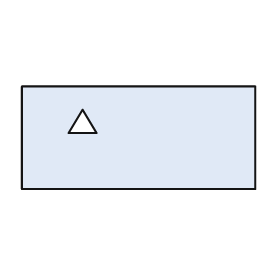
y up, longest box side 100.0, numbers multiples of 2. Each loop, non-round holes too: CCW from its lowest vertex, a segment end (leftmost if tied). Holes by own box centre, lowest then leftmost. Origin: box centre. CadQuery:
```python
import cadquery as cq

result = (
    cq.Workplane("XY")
    .moveTo(-50.0, -22.0)
    .lineTo(50.0, -22.0)
    .lineTo(50.0, 22.0)
    .lineTo(-50.0, 22.0)
    .close()
    .moveTo(-30.0, 2.0)
    .lineTo(-18.0, 2.0)
    .lineTo(-24.0, 12.0)
    .close()
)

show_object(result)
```